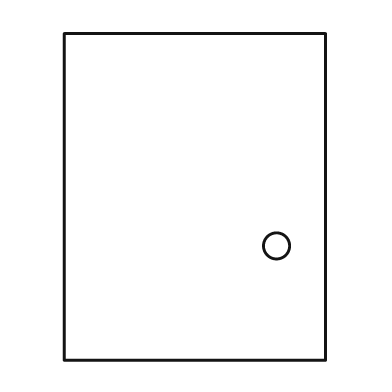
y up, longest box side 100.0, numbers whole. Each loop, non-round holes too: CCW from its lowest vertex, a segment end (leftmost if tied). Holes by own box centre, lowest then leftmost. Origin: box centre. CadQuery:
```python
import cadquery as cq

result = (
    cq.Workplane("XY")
    .moveTo(-40.0, -50.0)
    .lineTo(40.0, -50.0)
    .lineTo(40.0, 50.0)
    .lineTo(-40.0, 50.0)
    .close()
    .moveTo(25.0, -15.0)
    .circle(4.0)
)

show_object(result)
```